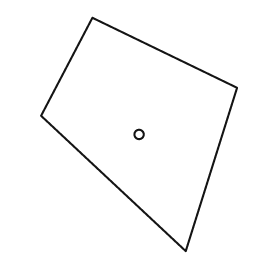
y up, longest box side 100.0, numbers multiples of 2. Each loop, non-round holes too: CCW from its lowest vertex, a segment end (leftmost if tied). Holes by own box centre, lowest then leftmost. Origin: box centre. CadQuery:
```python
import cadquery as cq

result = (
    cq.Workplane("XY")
    .moveTo(20.0, -50.0)
    .lineTo(42.0, 20.0)
    .lineTo(-20.0, 50.0)
    .lineTo(-42.0, 8.0)
    .close()
    .moveTo(0.0, 0.0)
    .circle(2.0)
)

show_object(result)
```